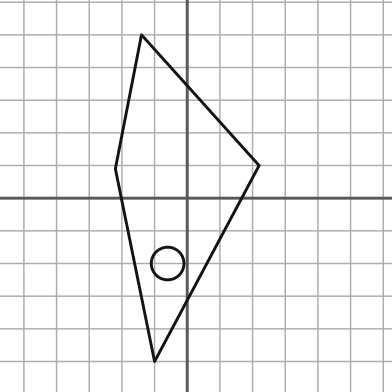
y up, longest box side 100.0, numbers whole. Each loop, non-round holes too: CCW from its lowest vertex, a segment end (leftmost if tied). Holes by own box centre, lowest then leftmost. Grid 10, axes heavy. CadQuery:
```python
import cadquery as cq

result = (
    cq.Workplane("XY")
    .moveTo(-10.0, -50.0)
    .lineTo(22.0, 10.0)
    .lineTo(-14.0, 50.0)
    .lineTo(-22.0, 9.0)
    .close()
    .moveTo(-6.0, -20.0)
    .circle(5.0)
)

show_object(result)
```